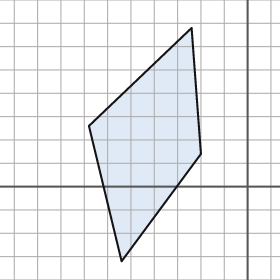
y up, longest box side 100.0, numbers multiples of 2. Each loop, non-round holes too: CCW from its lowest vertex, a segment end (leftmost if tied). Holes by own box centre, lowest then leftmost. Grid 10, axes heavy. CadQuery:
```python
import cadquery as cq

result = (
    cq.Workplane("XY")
    .moveTo(-54.0, -32.0)
    .lineTo(-20.0, 14.0)
    .lineTo(-24.0, 68.0)
    .lineTo(-68.0, 26.0)
    .close()
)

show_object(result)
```